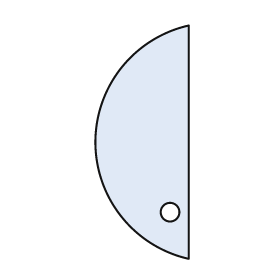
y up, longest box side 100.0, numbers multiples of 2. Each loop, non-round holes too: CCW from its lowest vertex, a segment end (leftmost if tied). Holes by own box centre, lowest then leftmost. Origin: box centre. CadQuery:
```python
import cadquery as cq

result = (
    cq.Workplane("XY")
    .moveTo(20.0, -50.0)
    .lineTo(20.0, 50.0)
    .threePointArc((-20.0, 0.0), (20.0, -50.0))
    .close()
    .moveTo(12.0, -30.0)
    .circle(4.0)
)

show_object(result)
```